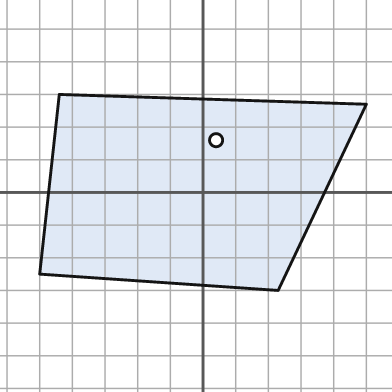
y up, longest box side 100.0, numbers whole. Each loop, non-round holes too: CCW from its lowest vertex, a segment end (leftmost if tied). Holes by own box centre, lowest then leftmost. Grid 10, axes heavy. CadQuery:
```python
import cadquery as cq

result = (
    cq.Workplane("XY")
    .moveTo(23.0, -30.0)
    .lineTo(50.0, 27.0)
    .lineTo(-44.0, 30.0)
    .lineTo(-50.0, -25.0)
    .close()
    .moveTo(4.0, 16.0)
    .circle(2.0)
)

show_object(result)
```